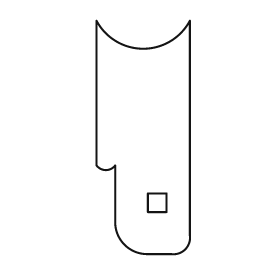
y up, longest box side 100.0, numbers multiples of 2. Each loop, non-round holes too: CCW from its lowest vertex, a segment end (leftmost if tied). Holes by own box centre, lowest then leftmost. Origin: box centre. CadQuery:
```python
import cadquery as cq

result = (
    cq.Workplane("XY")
    .moveTo(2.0, -50.0)
    .lineTo(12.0, -50.0)
    .threePointArc((18.0, -48.0), (20.0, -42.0))
    .lineTo(20.0, 50.0)
    .threePointArc((0.0, 38.0), (-20.0, 50.0))
    .lineTo(-20.0, -12.0)
    .threePointArc((-16.0, -14.0), (-12.0, -12.0))
    .lineTo(-12.0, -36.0)
    .threePointArc((-8.0, -46.0), (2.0, -50.0))
    .close()
    .moveTo(2.0, -32.0)
    .lineTo(10.0, -32.0)
    .lineTo(10.0, -24.0)
    .lineTo(2.0, -24.0)
    .close()
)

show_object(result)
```